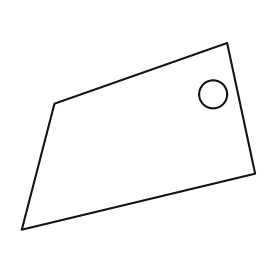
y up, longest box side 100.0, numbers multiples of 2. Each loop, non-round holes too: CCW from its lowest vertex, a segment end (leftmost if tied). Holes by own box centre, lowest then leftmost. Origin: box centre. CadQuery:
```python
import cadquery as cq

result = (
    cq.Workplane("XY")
    .moveTo(-50.0, -40.0)
    .lineTo(50.0, -16.0)
    .lineTo(38.0, 40.0)
    .lineTo(-36.0, 14.0)
    .close()
    .moveTo(32.0, 18.0)
    .circle(6.0)
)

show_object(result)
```